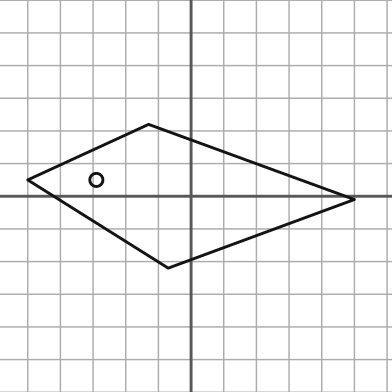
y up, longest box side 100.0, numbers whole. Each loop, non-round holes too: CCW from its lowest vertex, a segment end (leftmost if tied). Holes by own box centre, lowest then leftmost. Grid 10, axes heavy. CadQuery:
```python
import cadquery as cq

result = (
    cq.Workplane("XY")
    .moveTo(-7.0, -22.0)
    .lineTo(50.0, -1.0)
    .lineTo(-13.0, 22.0)
    .lineTo(-50.0, 5.0)
    .close()
    .moveTo(-29.0, 5.0)
    .circle(2.0)
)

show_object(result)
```